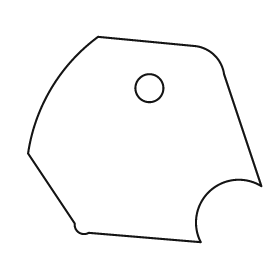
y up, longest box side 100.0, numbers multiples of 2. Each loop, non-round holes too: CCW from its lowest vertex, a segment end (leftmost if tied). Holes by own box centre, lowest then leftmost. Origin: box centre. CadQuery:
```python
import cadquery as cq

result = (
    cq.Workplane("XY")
    .moveTo(24.0, -44.0)
    .threePointArc((28.0, -22.0), (50.0, -20.0))
    .lineTo(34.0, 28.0)
    .threePointArc((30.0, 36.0), (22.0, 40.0))
    .lineTo(-20.0, 44.0)
    .threePointArc((-40.0, 22.0), (-50.0, -6.0))
    .lineTo(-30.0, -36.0)
    .threePointArc((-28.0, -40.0), (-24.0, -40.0))
    .close()
    .moveTo(2.0, 22.0)
    .circle(6.0)
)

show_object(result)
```